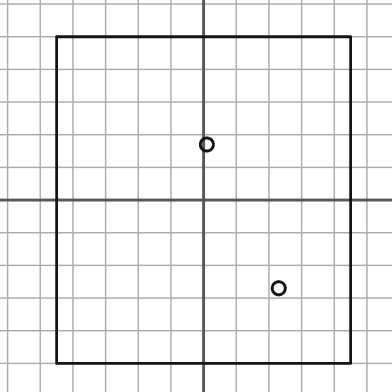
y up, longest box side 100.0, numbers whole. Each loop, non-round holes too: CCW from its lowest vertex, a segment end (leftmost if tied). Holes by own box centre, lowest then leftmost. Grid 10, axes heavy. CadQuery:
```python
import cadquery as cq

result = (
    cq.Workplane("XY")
    .moveTo(-45.0, -50.0)
    .lineTo(45.0, -50.0)
    .lineTo(45.0, 50.0)
    .lineTo(-45.0, 50.0)
    .close()
    .moveTo(23.0, -27.0)
    .circle(2.0)
    .moveTo(1.0, 17.0)
    .circle(2.0)
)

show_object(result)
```